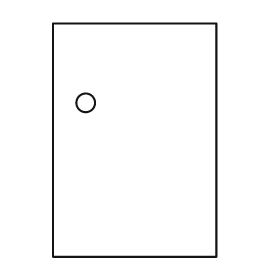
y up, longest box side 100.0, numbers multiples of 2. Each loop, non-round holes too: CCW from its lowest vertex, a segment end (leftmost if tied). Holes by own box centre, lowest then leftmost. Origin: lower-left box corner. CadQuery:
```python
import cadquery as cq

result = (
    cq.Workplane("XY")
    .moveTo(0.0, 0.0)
    .lineTo(70.0, 0.0)
    .lineTo(70.0, 100.0)
    .lineTo(0.0, 100.0)
    .close()
    .moveTo(14.0, 66.0)
    .circle(4.0)
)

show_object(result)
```